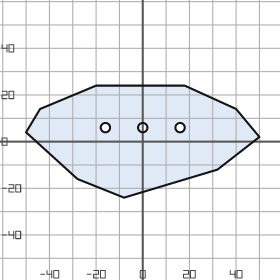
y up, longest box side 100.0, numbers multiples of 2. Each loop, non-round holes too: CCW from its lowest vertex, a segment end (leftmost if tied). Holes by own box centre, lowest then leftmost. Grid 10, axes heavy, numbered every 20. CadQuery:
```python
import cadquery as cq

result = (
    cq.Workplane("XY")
    .moveTo(-8.0, -24.0)
    .lineTo(32.0, -12.0)
    .lineTo(50.0, 2.0)
    .lineTo(40.0, 14.0)
    .lineTo(18.0, 24.0)
    .lineTo(-20.0, 24.0)
    .lineTo(-44.0, 14.0)
    .lineTo(-50.0, 4.0)
    .lineTo(-28.0, -16.0)
    .close()
    .moveTo(-16.0, 6.0)
    .circle(2.0)
    .moveTo(0.0, 6.0)
    .circle(2.0)
    .moveTo(16.0, 6.0)
    .circle(2.0)
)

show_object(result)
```